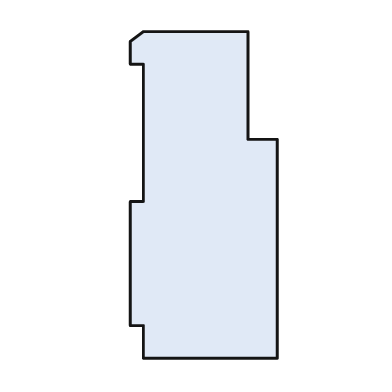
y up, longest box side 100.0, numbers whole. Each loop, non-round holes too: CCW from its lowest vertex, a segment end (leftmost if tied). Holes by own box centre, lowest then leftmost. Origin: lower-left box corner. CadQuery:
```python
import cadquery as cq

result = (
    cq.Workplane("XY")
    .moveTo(4.0, 0.0)
    .lineTo(45.0, 0.0)
    .lineTo(45.0, 67.0)
    .lineTo(36.0, 67.0)
    .lineTo(36.0, 100.0)
    .lineTo(4.0, 100.0)
    .lineTo(0.0, 97.0)
    .lineTo(0.0, 90.0)
    .lineTo(4.0, 90.0)
    .lineTo(4.0, 48.0)
    .lineTo(0.0, 48.0)
    .lineTo(0.0, 10.0)
    .lineTo(4.0, 10.0)
    .close()
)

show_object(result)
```